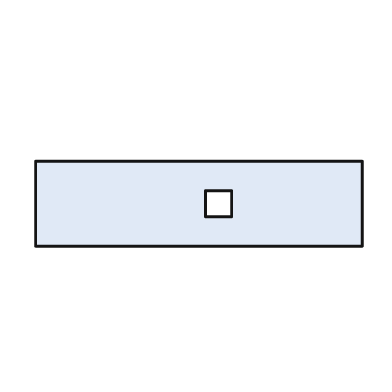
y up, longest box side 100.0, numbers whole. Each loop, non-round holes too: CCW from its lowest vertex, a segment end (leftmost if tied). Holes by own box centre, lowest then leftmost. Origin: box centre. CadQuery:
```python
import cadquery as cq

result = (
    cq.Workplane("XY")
    .moveTo(-50.0, -13.0)
    .lineTo(50.0, -13.0)
    .lineTo(50.0, 13.0)
    .lineTo(-50.0, 13.0)
    .close()
    .moveTo(2.0, -4.0)
    .lineTo(10.0, -4.0)
    .lineTo(10.0, 4.0)
    .lineTo(2.0, 4.0)
    .close()
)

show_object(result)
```